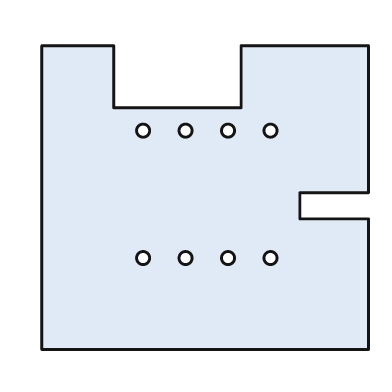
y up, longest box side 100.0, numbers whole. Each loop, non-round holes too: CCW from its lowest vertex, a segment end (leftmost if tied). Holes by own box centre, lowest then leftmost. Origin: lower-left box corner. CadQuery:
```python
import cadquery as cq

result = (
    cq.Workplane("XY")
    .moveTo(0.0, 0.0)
    .lineTo(100.0, 0.0)
    .lineTo(100.0, 40.0)
    .lineTo(79.0, 40.0)
    .lineTo(79.0, 48.0)
    .lineTo(100.0, 48.0)
    .lineTo(100.0, 93.0)
    .lineTo(61.0, 93.0)
    .lineTo(61.0, 74.0)
    .lineTo(22.0, 74.0)
    .lineTo(22.0, 93.0)
    .lineTo(0.0, 93.0)
    .close()
    .moveTo(31.0, 28.0)
    .circle(2.0)
    .moveTo(44.0, 28.0)
    .circle(2.0)
    .moveTo(57.0, 28.0)
    .circle(2.0)
    .moveTo(70.0, 28.0)
    .circle(2.0)
    .moveTo(31.0, 67.0)
    .circle(2.0)
    .moveTo(44.0, 67.0)
    .circle(2.0)
    .moveTo(57.0, 67.0)
    .circle(2.0)
    .moveTo(70.0, 67.0)
    .circle(2.0)
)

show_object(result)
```